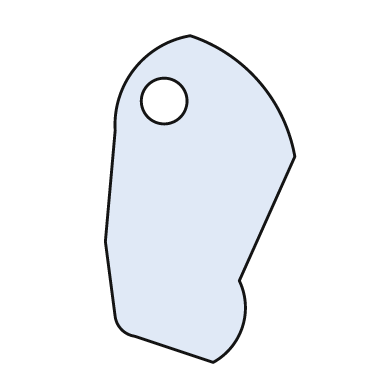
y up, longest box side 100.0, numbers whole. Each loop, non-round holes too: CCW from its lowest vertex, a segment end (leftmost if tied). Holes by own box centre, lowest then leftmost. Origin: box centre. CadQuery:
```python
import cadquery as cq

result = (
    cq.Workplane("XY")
    .moveTo(4.0, -50.0)
    .threePointArc((13.0, -39.0), (12.0, -25.0))
    .lineTo(29.0, 13.0)
    .threePointArc((18.0, 36.0), (-3.0, 50.0))
    .threePointArc((-20.0, 40.0), (-26.0, 21.0))
    .lineTo(-29.0, -13.0)
    .lineTo(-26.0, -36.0)
    .threePointArc((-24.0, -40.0), (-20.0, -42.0))
    .close()
    .moveTo(-11.0, 30.0)
    .circle(7.0)
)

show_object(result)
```